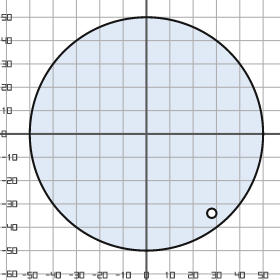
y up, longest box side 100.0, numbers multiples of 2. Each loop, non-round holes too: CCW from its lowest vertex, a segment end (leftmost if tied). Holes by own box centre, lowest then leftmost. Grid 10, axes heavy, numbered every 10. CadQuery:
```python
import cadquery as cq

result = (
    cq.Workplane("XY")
    .moveTo(0.0, 0.0)
    .circle(50.0)
    .moveTo(28.0, -34.0)
    .circle(2.0)
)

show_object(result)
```